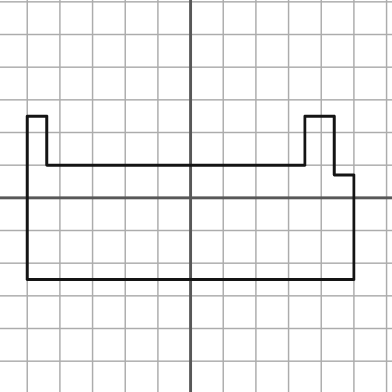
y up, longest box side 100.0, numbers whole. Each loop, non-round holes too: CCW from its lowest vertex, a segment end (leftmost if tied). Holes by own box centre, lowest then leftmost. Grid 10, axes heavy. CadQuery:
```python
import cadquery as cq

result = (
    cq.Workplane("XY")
    .moveTo(-50.0, -25.0)
    .lineTo(50.0, -25.0)
    .lineTo(50.0, 7.0)
    .lineTo(44.0, 7.0)
    .lineTo(44.0, 25.0)
    .lineTo(35.0, 25.0)
    .lineTo(35.0, 10.0)
    .lineTo(-44.0, 10.0)
    .lineTo(-44.0, 25.0)
    .lineTo(-50.0, 25.0)
    .close()
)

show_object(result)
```